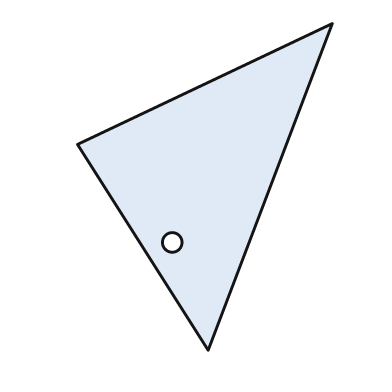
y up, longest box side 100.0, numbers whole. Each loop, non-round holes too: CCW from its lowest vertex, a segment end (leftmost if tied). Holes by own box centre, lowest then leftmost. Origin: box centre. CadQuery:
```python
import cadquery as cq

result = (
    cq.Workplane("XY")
    .moveTo(1.0, -50.0)
    .lineTo(39.0, 50.0)
    .lineTo(-39.0, 13.0)
    .close()
    .moveTo(-10.0, -17.0)
    .circle(3.0)
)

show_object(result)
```